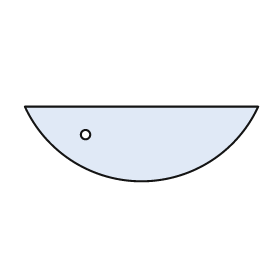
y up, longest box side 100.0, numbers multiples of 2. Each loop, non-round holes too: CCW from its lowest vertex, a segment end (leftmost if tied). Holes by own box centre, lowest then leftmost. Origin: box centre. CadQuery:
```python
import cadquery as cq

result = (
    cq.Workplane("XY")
    .moveTo(-50.0, 16.0)
    .threePointArc((0.0, -16.0), (50.0, 16.0))
    .close()
    .moveTo(-24.0, 4.0)
    .circle(2.0)
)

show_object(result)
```